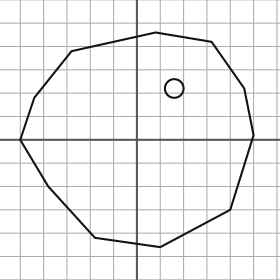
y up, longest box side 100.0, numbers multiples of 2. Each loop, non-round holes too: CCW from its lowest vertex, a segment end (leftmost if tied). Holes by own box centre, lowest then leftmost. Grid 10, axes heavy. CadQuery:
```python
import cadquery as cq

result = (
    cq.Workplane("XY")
    .moveTo(10.0, -46.0)
    .lineTo(40.0, -30.0)
    .lineTo(50.0, 2.0)
    .lineTo(46.0, 22.0)
    .lineTo(32.0, 42.0)
    .lineTo(8.0, 46.0)
    .lineTo(-28.0, 38.0)
    .lineTo(-44.0, 18.0)
    .lineTo(-50.0, 0.0)
    .lineTo(-38.0, -20.0)
    .lineTo(-18.0, -42.0)
    .close()
    .moveTo(16.0, 22.0)
    .circle(4.0)
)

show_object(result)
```